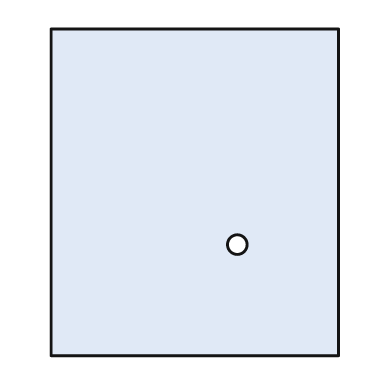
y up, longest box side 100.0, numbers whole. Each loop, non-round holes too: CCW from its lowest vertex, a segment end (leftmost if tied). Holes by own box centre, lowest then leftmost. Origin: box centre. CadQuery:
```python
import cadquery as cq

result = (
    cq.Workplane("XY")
    .moveTo(-44.0, -50.0)
    .lineTo(44.0, -50.0)
    .lineTo(44.0, 50.0)
    .lineTo(-44.0, 50.0)
    .close()
    .moveTo(13.0, -16.0)
    .circle(3.0)
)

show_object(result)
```